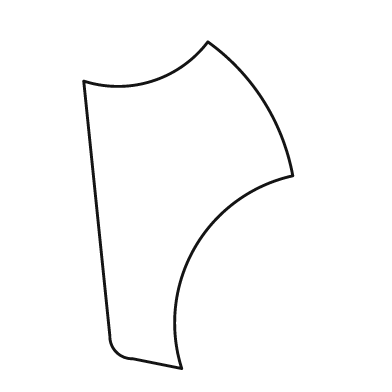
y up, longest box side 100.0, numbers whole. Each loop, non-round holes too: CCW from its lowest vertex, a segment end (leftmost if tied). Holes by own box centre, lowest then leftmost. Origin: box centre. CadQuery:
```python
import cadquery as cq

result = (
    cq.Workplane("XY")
    .moveTo(-2.0, -50.0)
    .threePointArc((2.0, -13.0), (32.0, 9.0))
    .threePointArc((23.0, 32.0), (6.0, 50.0))
    .threePointArc((-11.0, 38.0), (-32.0, 38.0))
    .lineTo(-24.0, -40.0)
    .threePointArc((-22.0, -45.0), (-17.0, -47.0))
    .close()
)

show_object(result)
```